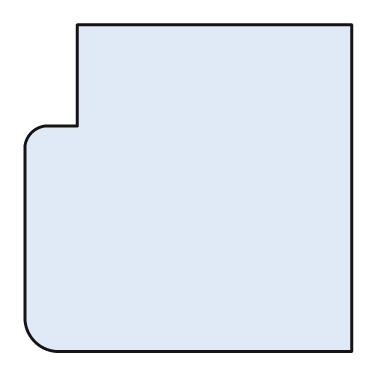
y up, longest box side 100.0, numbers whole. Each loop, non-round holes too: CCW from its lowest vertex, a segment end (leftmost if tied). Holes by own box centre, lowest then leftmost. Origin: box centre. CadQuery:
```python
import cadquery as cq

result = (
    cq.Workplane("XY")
    .moveTo(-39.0, -50.0)
    .lineTo(50.0, -50.0)
    .lineTo(50.0, 50.0)
    .lineTo(-34.0, 50.0)
    .lineTo(-34.0, 19.0)
    .lineTo(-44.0, 19.0)
    .threePointArc((-48.0, 17.0), (-50.0, 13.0))
    .lineTo(-50.0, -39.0)
    .threePointArc((-47.0, -47.0), (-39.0, -50.0))
    .close()
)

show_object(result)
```